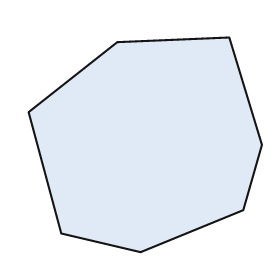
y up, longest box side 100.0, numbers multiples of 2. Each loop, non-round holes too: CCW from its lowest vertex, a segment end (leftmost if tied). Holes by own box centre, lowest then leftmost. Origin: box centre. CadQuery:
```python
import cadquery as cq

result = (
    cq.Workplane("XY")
    .moveTo(-2.0, -46.0)
    .lineTo(42.0, -28.0)
    .lineTo(50.0, 0.0)
    .lineTo(36.0, 46.0)
    .lineTo(-12.0, 44.0)
    .lineTo(-50.0, 14.0)
    .lineTo(-36.0, -38.0)
    .close()
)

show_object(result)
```